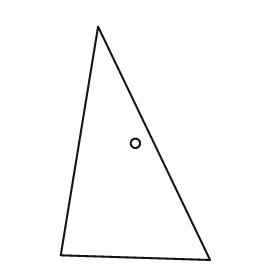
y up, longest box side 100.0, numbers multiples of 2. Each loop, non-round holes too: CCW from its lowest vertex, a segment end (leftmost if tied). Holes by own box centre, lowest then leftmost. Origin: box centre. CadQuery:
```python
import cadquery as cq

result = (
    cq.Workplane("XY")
    .moveTo(32.0, -50.0)
    .lineTo(-16.0, 50.0)
    .lineTo(-32.0, -48.0)
    .close()
    .moveTo(0.0, 0.0)
    .circle(2.0)
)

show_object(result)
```